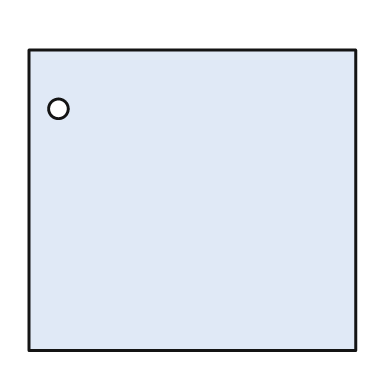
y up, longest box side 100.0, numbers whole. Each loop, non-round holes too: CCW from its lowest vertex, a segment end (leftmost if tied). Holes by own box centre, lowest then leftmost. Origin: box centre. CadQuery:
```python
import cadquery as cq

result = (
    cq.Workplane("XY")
    .moveTo(-50.0, -46.0)
    .lineTo(50.0, -46.0)
    .lineTo(50.0, 46.0)
    .lineTo(-50.0, 46.0)
    .close()
    .moveTo(-41.0, 28.0)
    .circle(3.0)
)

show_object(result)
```